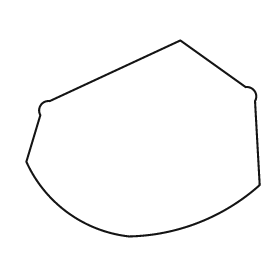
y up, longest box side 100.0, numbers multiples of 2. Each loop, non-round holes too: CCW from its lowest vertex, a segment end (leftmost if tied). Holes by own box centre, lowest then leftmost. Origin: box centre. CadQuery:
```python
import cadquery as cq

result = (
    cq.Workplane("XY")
    .moveTo(-6.0, -42.0)
    .threePointArc((24.0, -36.0), (50.0, -20.0))
    .lineTo(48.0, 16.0)
    .threePointArc((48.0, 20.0), (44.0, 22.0))
    .lineTo(16.0, 42.0)
    .lineTo(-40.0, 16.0)
    .threePointArc((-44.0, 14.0), (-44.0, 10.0))
    .lineTo(-50.0, -10.0)
    .threePointArc((-32.0, -32.0), (-6.0, -42.0))
    .close()
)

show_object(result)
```